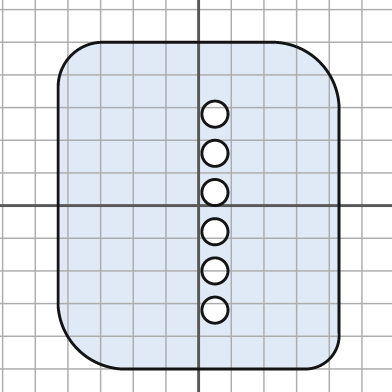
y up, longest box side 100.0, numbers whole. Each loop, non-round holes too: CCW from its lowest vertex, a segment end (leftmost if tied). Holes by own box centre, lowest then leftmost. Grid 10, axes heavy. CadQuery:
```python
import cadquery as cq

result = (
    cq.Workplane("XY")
    .moveTo(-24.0, -50.0)
    .lineTo(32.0, -50.0)
    .threePointArc((40.0, -47.0), (43.0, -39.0))
    .lineTo(43.0, 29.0)
    .threePointArc((37.0, 44.0), (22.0, 50.0))
    .lineTo(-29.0, 50.0)
    .threePointArc((-39.0, 46.0), (-43.0, 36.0))
    .lineTo(-43.0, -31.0)
    .threePointArc((-37.0, -44.0), (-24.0, -50.0))
    .close()
    .moveTo(5.0, -32.0)
    .circle(4.0)
    .moveTo(5.0, -20.0)
    .circle(4.0)
    .moveTo(5.0, -8.0)
    .circle(4.0)
    .moveTo(5.0, 4.0)
    .circle(4.0)
    .moveTo(5.0, 16.0)
    .circle(4.0)
    .moveTo(5.0, 28.0)
    .circle(4.0)
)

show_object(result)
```